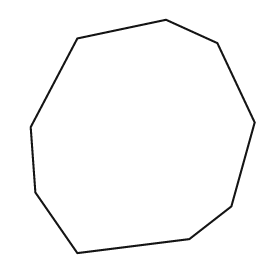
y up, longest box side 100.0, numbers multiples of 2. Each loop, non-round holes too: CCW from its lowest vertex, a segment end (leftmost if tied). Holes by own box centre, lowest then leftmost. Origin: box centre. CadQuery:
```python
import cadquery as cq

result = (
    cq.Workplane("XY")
    .moveTo(-28.0, -50.0)
    .lineTo(20.0, -44.0)
    .lineTo(38.0, -30.0)
    .lineTo(48.0, 6.0)
    .lineTo(32.0, 40.0)
    .lineTo(10.0, 50.0)
    .lineTo(-28.0, 42.0)
    .lineTo(-48.0, 4.0)
    .lineTo(-46.0, -24.0)
    .close()
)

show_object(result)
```